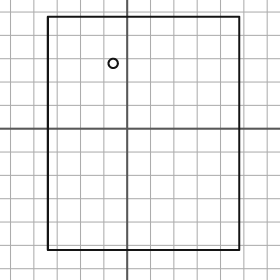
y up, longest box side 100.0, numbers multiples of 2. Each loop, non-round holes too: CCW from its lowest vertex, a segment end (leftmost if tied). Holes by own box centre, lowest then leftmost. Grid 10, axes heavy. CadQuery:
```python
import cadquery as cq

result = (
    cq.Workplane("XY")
    .moveTo(-34.0, -52.0)
    .lineTo(48.0, -52.0)
    .lineTo(48.0, 48.0)
    .lineTo(-34.0, 48.0)
    .close()
    .moveTo(-6.0, 28.0)
    .circle(2.0)
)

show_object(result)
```